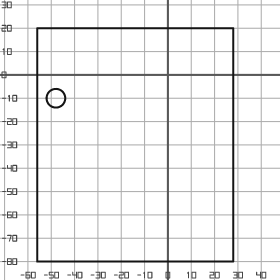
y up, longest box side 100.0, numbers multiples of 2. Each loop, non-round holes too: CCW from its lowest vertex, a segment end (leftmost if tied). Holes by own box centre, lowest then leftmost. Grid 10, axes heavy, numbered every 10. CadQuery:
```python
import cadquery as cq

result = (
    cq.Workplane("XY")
    .moveTo(-56.0, -80.0)
    .lineTo(28.0, -80.0)
    .lineTo(28.0, 20.0)
    .lineTo(-56.0, 20.0)
    .close()
    .moveTo(-48.0, -10.0)
    .circle(4.0)
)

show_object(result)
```